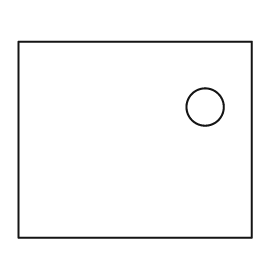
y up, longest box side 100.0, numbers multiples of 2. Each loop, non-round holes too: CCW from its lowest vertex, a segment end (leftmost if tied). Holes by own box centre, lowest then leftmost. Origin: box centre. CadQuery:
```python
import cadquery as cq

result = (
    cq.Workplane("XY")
    .moveTo(-50.0, -42.0)
    .lineTo(50.0, -42.0)
    .lineTo(50.0, 42.0)
    .lineTo(-50.0, 42.0)
    .close()
    .moveTo(30.0, 14.0)
    .circle(8.0)
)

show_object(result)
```